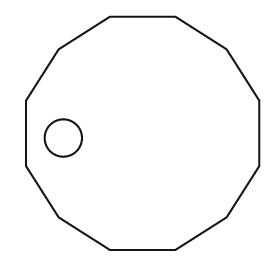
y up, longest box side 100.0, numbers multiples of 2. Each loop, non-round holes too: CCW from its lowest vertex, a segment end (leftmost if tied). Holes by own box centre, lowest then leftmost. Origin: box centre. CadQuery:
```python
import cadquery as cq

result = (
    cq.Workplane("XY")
    .moveTo(-14.0, -50.0)
    .lineTo(14.0, -50.0)
    .lineTo(36.0, -36.0)
    .lineTo(50.0, -14.0)
    .lineTo(50.0, 14.0)
    .lineTo(36.0, 36.0)
    .lineTo(14.0, 50.0)
    .lineTo(-14.0, 50.0)
    .lineTo(-36.0, 36.0)
    .lineTo(-50.0, 14.0)
    .lineTo(-50.0, -14.0)
    .lineTo(-36.0, -36.0)
    .close()
    .moveTo(-34.0, -2.0)
    .circle(8.0)
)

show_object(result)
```